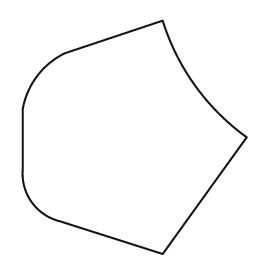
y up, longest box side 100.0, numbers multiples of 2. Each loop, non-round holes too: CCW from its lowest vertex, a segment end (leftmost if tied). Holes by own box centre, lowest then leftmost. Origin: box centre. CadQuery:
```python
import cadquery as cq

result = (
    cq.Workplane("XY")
    .moveTo(12.0, -50.0)
    .lineTo(48.0, 0.0)
    .threePointArc((26.0, 22.0), (12.0, 50.0))
    .lineTo(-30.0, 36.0)
    .threePointArc((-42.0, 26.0), (-48.0, 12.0))
    .lineTo(-48.0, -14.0)
    .threePointArc((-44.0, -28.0), (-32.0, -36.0))
    .close()
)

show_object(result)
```